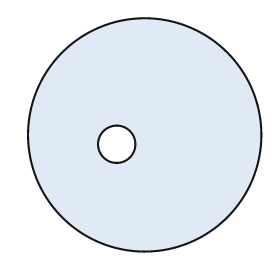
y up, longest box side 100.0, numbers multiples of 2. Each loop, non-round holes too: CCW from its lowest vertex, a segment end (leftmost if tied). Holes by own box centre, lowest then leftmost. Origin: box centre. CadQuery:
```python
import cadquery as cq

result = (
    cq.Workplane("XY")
    .moveTo(0.0, 0.0)
    .circle(50.0)
    .moveTo(-12.0, -4.0)
    .circle(8.0)
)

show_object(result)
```